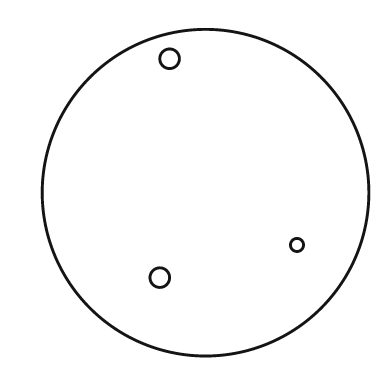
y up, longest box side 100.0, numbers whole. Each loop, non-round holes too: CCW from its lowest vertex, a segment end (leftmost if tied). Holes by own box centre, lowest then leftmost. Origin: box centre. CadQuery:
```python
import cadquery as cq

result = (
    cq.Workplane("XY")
    .moveTo(0.0, 0.0)
    .circle(50.0)
    .moveTo(-14.0, -26.0)
    .circle(3.0)
    .moveTo(28.0, -16.0)
    .circle(2.0)
    .moveTo(-11.0, 41.0)
    .circle(3.0)
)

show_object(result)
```